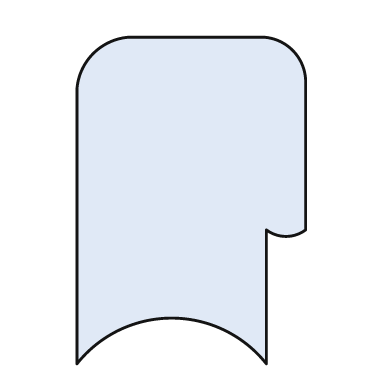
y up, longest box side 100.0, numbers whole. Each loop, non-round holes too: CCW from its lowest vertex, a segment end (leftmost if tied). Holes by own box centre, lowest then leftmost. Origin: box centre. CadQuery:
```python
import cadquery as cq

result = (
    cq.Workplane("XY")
    .moveTo(-35.0, -50.0)
    .threePointArc((-6.0, -36.0), (23.0, -50.0))
    .lineTo(23.0, -9.0)
    .threePointArc((29.0, -11.0), (35.0, -9.0))
    .lineTo(35.0, 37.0)
    .threePointArc((31.0, 46.0), (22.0, 50.0))
    .lineTo(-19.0, 50.0)
    .threePointArc((-30.0, 45.0), (-35.0, 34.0))
    .close()
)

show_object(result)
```